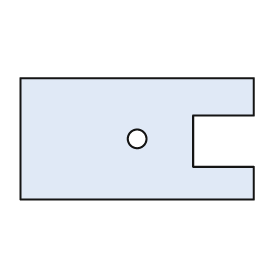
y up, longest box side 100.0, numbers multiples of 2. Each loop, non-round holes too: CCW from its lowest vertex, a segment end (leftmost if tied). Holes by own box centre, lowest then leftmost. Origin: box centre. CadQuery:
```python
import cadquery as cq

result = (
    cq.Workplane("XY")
    .moveTo(-50.0, -26.0)
    .lineTo(50.0, -26.0)
    .lineTo(50.0, -12.0)
    .lineTo(24.0, -12.0)
    .lineTo(24.0, 10.0)
    .lineTo(50.0, 10.0)
    .lineTo(50.0, 26.0)
    .lineTo(-50.0, 26.0)
    .close()
    .moveTo(0.0, 0.0)
    .circle(4.0)
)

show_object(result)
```